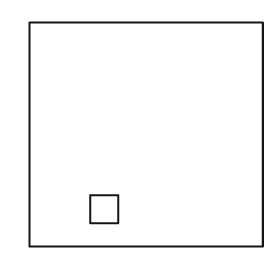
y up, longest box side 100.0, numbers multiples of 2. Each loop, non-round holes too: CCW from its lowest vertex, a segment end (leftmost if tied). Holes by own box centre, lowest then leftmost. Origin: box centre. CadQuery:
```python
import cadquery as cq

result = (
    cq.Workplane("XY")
    .moveTo(-50.0, -48.0)
    .lineTo(50.0, -48.0)
    .lineTo(50.0, 48.0)
    .lineTo(-50.0, 48.0)
    .close()
    .moveTo(-24.0, -38.0)
    .lineTo(-12.0, -38.0)
    .lineTo(-12.0, -26.0)
    .lineTo(-24.0, -26.0)
    .close()
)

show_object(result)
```